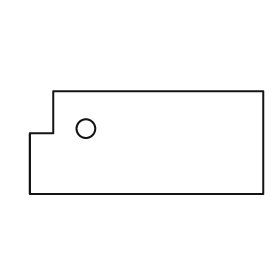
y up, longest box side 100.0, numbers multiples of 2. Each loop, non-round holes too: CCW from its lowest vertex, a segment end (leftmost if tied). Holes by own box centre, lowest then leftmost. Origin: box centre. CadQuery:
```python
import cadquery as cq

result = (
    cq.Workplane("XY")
    .moveTo(-50.0, -22.0)
    .lineTo(50.0, -22.0)
    .lineTo(50.0, 22.0)
    .lineTo(-40.0, 22.0)
    .lineTo(-40.0, 4.0)
    .lineTo(-50.0, 4.0)
    .close()
    .moveTo(-26.0, 6.0)
    .circle(4.0)
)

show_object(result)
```